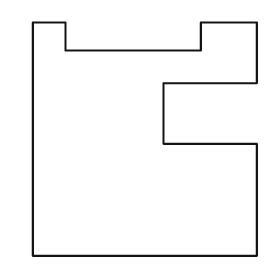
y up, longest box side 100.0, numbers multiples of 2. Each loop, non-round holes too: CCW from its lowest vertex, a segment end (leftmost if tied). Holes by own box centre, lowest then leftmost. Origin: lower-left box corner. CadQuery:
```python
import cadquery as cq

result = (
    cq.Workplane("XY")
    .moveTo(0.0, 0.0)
    .lineTo(96.0, 0.0)
    .lineTo(96.0, 48.0)
    .lineTo(56.0, 48.0)
    .lineTo(56.0, 74.0)
    .lineTo(96.0, 74.0)
    .lineTo(96.0, 100.0)
    .lineTo(72.0, 100.0)
    .lineTo(72.0, 88.0)
    .lineTo(14.0, 88.0)
    .lineTo(14.0, 100.0)
    .lineTo(0.0, 100.0)
    .close()
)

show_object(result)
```